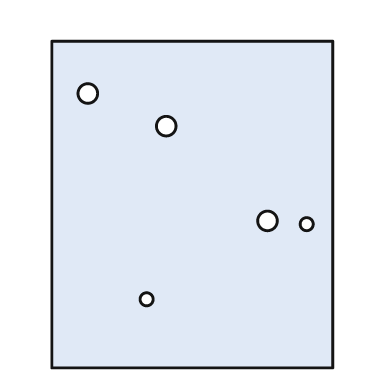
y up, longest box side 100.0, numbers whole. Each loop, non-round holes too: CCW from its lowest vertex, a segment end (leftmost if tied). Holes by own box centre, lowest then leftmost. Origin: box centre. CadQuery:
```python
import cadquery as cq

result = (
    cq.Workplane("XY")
    .moveTo(-43.0, -50.0)
    .lineTo(43.0, -50.0)
    .lineTo(43.0, 50.0)
    .lineTo(-43.0, 50.0)
    .close()
    .moveTo(-14.0, -29.0)
    .circle(2.0)
    .moveTo(35.0, -6.0)
    .circle(2.0)
    .moveTo(23.0, -5.0)
    .circle(3.0)
    .moveTo(-8.0, 24.0)
    .circle(3.0)
    .moveTo(-32.0, 34.0)
    .circle(3.0)
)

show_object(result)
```